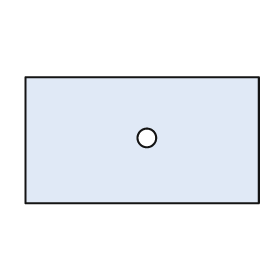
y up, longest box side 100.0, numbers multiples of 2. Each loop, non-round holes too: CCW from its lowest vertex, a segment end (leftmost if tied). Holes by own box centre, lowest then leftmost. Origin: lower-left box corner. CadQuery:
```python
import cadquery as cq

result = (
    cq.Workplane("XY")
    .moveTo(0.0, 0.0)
    .lineTo(100.0, 0.0)
    .lineTo(100.0, 54.0)
    .lineTo(0.0, 54.0)
    .close()
    .moveTo(52.0, 28.0)
    .circle(4.0)
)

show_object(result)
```